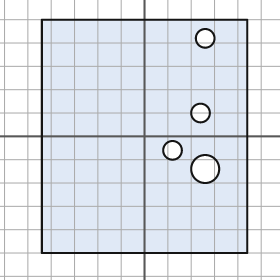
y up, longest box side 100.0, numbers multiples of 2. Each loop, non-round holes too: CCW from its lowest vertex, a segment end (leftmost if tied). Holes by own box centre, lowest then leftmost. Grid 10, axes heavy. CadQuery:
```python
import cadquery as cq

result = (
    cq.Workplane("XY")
    .moveTo(-44.0, -50.0)
    .lineTo(44.0, -50.0)
    .lineTo(44.0, 50.0)
    .lineTo(-44.0, 50.0)
    .close()
    .moveTo(26.0, -14.0)
    .circle(6.0)
    .moveTo(12.0, -6.0)
    .circle(4.0)
    .moveTo(24.0, 10.0)
    .circle(4.0)
    .moveTo(26.0, 42.0)
    .circle(4.0)
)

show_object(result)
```